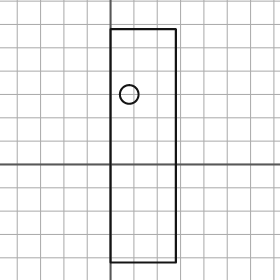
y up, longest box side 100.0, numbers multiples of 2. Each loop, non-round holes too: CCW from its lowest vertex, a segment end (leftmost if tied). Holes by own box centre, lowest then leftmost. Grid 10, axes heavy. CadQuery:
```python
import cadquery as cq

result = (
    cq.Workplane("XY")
    .moveTo(0.0, -42.0)
    .lineTo(28.0, -42.0)
    .lineTo(28.0, 58.0)
    .lineTo(0.0, 58.0)
    .close()
    .moveTo(8.0, 30.0)
    .circle(4.0)
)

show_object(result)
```